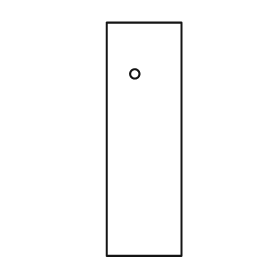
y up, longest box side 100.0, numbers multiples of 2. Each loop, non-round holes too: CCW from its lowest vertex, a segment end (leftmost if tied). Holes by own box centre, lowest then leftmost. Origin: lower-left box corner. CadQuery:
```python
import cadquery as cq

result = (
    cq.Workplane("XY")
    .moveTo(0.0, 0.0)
    .lineTo(32.0, 0.0)
    .lineTo(32.0, 100.0)
    .lineTo(0.0, 100.0)
    .close()
    .moveTo(12.0, 78.0)
    .circle(2.0)
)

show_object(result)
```